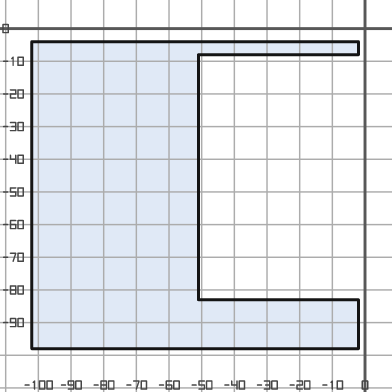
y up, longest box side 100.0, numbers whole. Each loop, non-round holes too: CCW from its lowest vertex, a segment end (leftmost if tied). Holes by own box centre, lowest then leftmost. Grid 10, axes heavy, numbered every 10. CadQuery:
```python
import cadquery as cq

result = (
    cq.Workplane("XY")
    .moveTo(-102.0, -98.0)
    .lineTo(-2.0, -98.0)
    .lineTo(-2.0, -83.0)
    .lineTo(-51.0, -83.0)
    .lineTo(-51.0, -8.0)
    .lineTo(-2.0, -8.0)
    .lineTo(-2.0, -4.0)
    .lineTo(-102.0, -4.0)
    .close()
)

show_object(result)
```